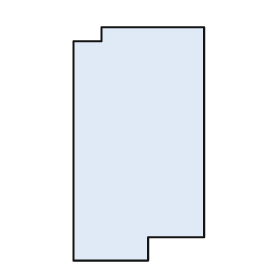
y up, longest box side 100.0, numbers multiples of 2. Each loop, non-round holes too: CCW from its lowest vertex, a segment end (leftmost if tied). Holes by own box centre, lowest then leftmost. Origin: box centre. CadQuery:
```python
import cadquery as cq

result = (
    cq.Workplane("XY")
    .moveTo(-28.0, -50.0)
    .lineTo(4.0, -50.0)
    .lineTo(4.0, -40.0)
    .lineTo(28.0, -40.0)
    .lineTo(28.0, 50.0)
    .lineTo(-16.0, 50.0)
    .lineTo(-16.0, 44.0)
    .lineTo(-28.0, 44.0)
    .close()
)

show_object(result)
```